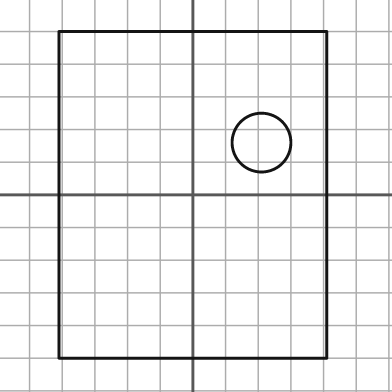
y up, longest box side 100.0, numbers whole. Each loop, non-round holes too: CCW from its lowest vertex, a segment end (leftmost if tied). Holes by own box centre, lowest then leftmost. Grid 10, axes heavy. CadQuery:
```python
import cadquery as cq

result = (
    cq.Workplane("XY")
    .moveTo(-41.0, -50.0)
    .lineTo(41.0, -50.0)
    .lineTo(41.0, 50.0)
    .lineTo(-41.0, 50.0)
    .close()
    .moveTo(21.0, 16.0)
    .circle(9.0)
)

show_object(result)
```